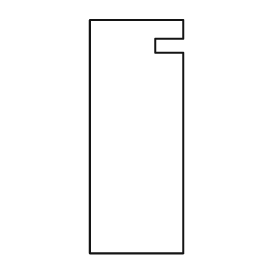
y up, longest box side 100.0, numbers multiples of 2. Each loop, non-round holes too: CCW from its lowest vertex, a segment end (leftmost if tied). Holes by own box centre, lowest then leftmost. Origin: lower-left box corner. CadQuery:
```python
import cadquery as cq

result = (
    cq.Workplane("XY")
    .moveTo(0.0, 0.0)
    .lineTo(40.0, 0.0)
    .lineTo(40.0, 86.0)
    .lineTo(28.0, 86.0)
    .lineTo(28.0, 92.0)
    .lineTo(40.0, 92.0)
    .lineTo(40.0, 100.0)
    .lineTo(0.0, 100.0)
    .close()
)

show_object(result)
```